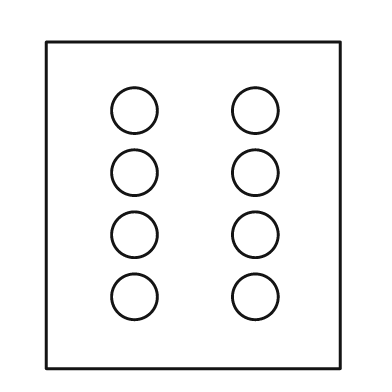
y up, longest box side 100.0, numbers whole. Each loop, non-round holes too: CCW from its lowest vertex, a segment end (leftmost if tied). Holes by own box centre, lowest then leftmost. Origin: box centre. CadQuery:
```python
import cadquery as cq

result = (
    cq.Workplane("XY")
    .moveTo(-45.0, -50.0)
    .lineTo(45.0, -50.0)
    .lineTo(45.0, 50.0)
    .lineTo(-45.0, 50.0)
    .close()
    .moveTo(-18.0, -28.0)
    .circle(7.0)
    .moveTo(19.0, -28.0)
    .circle(7.0)
    .moveTo(-18.0, -9.0)
    .circle(7.0)
    .moveTo(19.0, -9.0)
    .circle(7.0)
    .moveTo(-18.0, 10.0)
    .circle(7.0)
    .moveTo(19.0, 10.0)
    .circle(7.0)
    .moveTo(-18.0, 29.0)
    .circle(7.0)
    .moveTo(19.0, 29.0)
    .circle(7.0)
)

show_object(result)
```